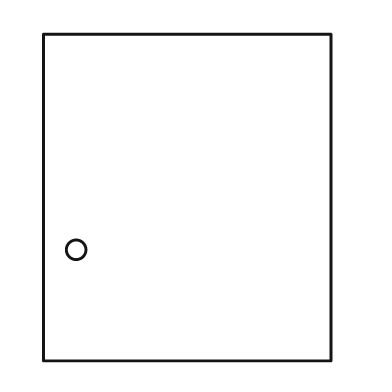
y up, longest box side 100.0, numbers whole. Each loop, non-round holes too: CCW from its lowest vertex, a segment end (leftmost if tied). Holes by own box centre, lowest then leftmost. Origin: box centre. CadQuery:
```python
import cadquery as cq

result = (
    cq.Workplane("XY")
    .moveTo(-44.0, -50.0)
    .lineTo(44.0, -50.0)
    .lineTo(44.0, 50.0)
    .lineTo(-44.0, 50.0)
    .close()
    .moveTo(-34.0, -16.0)
    .circle(3.0)
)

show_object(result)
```